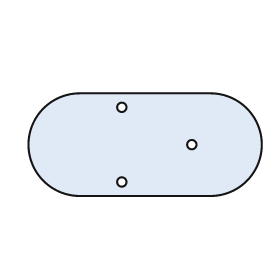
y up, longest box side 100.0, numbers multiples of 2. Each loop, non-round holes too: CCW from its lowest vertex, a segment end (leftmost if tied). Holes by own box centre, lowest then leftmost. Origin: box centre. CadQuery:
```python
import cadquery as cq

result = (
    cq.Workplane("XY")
    .moveTo(-28.0, -22.0)
    .lineTo(28.0, -22.0)
    .threePointArc((50.0, 0.0), (28.0, 22.0))
    .lineTo(-28.0, 22.0)
    .threePointArc((-50.0, 0.0), (-28.0, -22.0))
    .close()
    .moveTo(-10.0, -16.0)
    .circle(2.0)
    .moveTo(20.0, 0.0)
    .circle(2.0)
    .moveTo(-10.0, 16.0)
    .circle(2.0)
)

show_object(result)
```